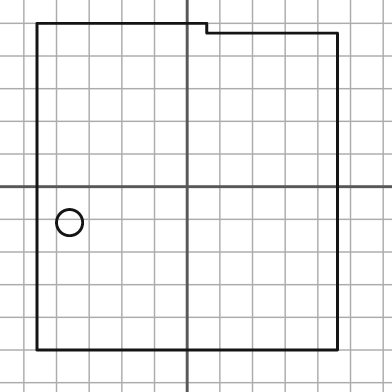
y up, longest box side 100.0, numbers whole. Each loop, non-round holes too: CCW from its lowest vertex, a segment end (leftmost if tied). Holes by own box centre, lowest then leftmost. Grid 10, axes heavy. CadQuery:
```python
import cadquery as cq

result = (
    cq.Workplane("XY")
    .moveTo(-46.0, -50.0)
    .lineTo(46.0, -50.0)
    .lineTo(46.0, 47.0)
    .lineTo(6.0, 47.0)
    .lineTo(6.0, 50.0)
    .lineTo(-46.0, 50.0)
    .close()
    .moveTo(-36.0, -11.0)
    .circle(4.0)
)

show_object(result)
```